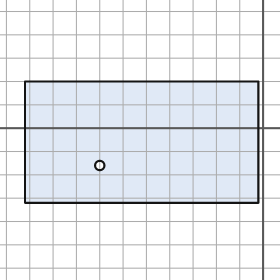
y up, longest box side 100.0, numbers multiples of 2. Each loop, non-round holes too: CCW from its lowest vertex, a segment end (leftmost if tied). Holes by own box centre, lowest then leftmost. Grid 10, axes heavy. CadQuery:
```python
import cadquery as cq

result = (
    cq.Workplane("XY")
    .moveTo(-102.0, -32.0)
    .lineTo(-2.0, -32.0)
    .lineTo(-2.0, 20.0)
    .lineTo(-102.0, 20.0)
    .close()
    .moveTo(-70.0, -16.0)
    .circle(2.0)
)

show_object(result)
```